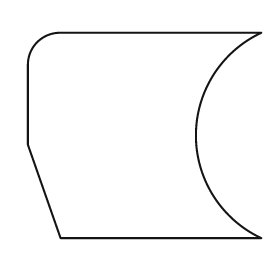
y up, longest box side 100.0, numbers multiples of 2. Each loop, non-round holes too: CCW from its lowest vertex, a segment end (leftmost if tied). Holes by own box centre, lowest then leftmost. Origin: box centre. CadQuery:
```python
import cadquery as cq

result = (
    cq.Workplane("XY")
    .moveTo(-36.0, -44.0)
    .lineTo(50.0, -44.0)
    .threePointArc((22.0, 0.0), (50.0, 44.0))
    .lineTo(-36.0, 44.0)
    .threePointArc((-46.0, 40.0), (-50.0, 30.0))
    .lineTo(-50.0, -4.0)
    .close()
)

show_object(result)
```